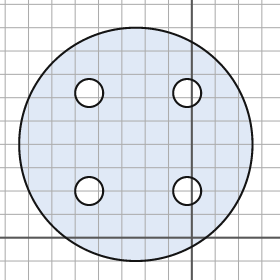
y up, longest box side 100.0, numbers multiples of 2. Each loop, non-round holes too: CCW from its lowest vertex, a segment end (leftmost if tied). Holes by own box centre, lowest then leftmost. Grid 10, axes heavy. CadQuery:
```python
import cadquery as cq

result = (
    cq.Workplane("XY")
    .moveTo(-24.0, 40.0)
    .circle(50.0)
    .moveTo(-44.0, 20.0)
    .circle(6.0)
    .moveTo(-2.0, 20.0)
    .circle(6.0)
    .moveTo(-44.0, 62.0)
    .circle(6.0)
    .moveTo(-2.0, 62.0)
    .circle(6.0)
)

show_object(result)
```